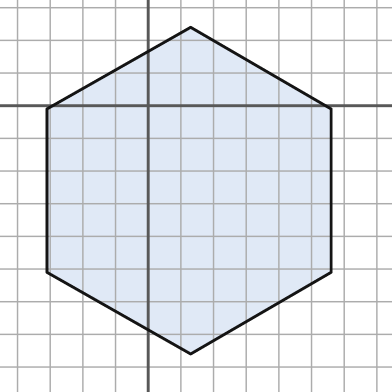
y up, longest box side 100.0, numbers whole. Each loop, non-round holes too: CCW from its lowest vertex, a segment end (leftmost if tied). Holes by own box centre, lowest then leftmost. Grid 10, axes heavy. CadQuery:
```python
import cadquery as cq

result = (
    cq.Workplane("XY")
    .moveTo(13.0, -76.0)
    .lineTo(56.0, -51.0)
    .lineTo(56.0, -1.0)
    .lineTo(13.0, 24.0)
    .lineTo(-31.0, -1.0)
    .lineTo(-31.0, -51.0)
    .close()
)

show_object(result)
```